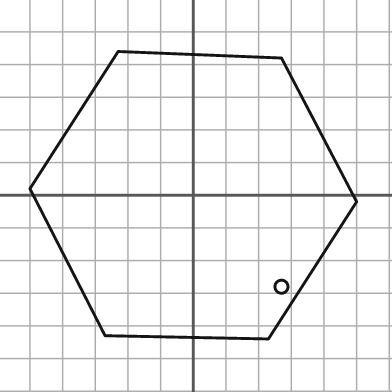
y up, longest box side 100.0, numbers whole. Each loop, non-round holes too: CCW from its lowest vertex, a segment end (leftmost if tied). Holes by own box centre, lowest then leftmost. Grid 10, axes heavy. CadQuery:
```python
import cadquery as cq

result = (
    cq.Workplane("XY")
    .moveTo(23.0, -44.0)
    .lineTo(50.0, -2.0)
    .lineTo(27.0, 42.0)
    .lineTo(-23.0, 44.0)
    .lineTo(-50.0, 2.0)
    .lineTo(-27.0, -43.0)
    .close()
    .moveTo(27.0, -28.0)
    .circle(2.0)
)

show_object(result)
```